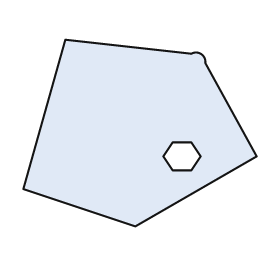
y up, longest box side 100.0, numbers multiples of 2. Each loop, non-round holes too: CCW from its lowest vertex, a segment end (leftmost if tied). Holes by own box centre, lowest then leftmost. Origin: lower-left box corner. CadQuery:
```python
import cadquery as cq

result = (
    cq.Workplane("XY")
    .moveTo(48.0, 0.0)
    .lineTo(100.0, 30.0)
    .lineTo(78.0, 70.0)
    .threePointArc((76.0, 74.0), (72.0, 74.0))
    .lineTo(18.0, 80.0)
    .lineTo(0.0, 16.0)
    .close()
    .moveTo(64.0, 24.0)
    .lineTo(72.0, 24.0)
    .lineTo(76.0, 30.0)
    .lineTo(72.0, 36.0)
    .lineTo(64.0, 36.0)
    .lineTo(60.0, 30.0)
    .close()
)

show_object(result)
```